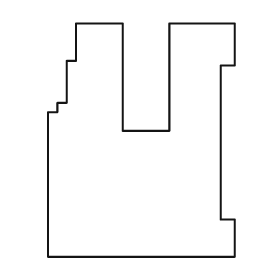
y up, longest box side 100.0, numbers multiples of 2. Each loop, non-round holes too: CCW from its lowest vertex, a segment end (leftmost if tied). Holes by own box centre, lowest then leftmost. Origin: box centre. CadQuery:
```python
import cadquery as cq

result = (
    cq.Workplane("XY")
    .moveTo(-40.0, -50.0)
    .lineTo(40.0, -50.0)
    .lineTo(40.0, -34.0)
    .lineTo(34.0, -34.0)
    .lineTo(34.0, 32.0)
    .lineTo(40.0, 32.0)
    .lineTo(40.0, 50.0)
    .lineTo(12.0, 50.0)
    .lineTo(12.0, 4.0)
    .lineTo(-8.0, 4.0)
    .lineTo(-8.0, 50.0)
    .lineTo(-28.0, 50.0)
    .lineTo(-28.0, 34.0)
    .lineTo(-32.0, 34.0)
    .lineTo(-32.0, 16.0)
    .lineTo(-36.0, 16.0)
    .lineTo(-36.0, 12.0)
    .lineTo(-40.0, 12.0)
    .close()
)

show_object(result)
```